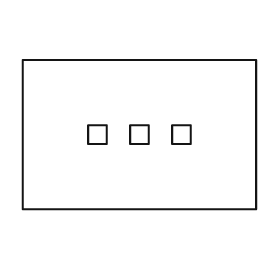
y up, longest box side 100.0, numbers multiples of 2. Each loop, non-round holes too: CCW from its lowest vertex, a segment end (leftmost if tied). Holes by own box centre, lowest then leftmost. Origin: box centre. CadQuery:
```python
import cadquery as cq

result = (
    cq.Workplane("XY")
    .moveTo(-50.0, -32.0)
    .lineTo(50.0, -32.0)
    .lineTo(50.0, 32.0)
    .lineTo(-50.0, 32.0)
    .close()
    .moveTo(-22.0, -4.0)
    .lineTo(-14.0, -4.0)
    .lineTo(-14.0, 4.0)
    .lineTo(-22.0, 4.0)
    .close()
    .moveTo(-4.0, -4.0)
    .lineTo(4.0, -4.0)
    .lineTo(4.0, 4.0)
    .lineTo(-4.0, 4.0)
    .close()
    .moveTo(14.0, -4.0)
    .lineTo(22.0, -4.0)
    .lineTo(22.0, 4.0)
    .lineTo(14.0, 4.0)
    .close()
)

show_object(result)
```